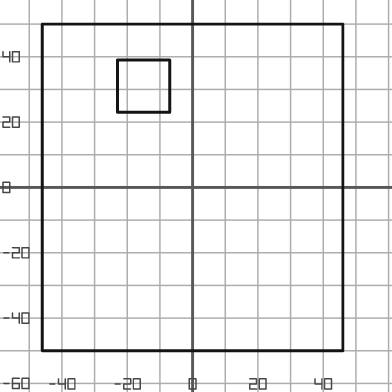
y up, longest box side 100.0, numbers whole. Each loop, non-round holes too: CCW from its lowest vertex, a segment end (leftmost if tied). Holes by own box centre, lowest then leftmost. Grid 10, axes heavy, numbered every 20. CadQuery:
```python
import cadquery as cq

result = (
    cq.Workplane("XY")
    .moveTo(-46.0, -50.0)
    .lineTo(46.0, -50.0)
    .lineTo(46.0, 50.0)
    .lineTo(-46.0, 50.0)
    .close()
    .moveTo(-23.0, 23.0)
    .lineTo(-7.0, 23.0)
    .lineTo(-7.0, 39.0)
    .lineTo(-23.0, 39.0)
    .close()
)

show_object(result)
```